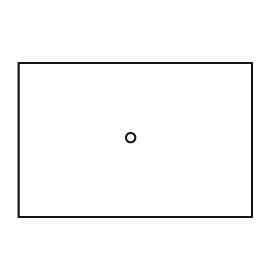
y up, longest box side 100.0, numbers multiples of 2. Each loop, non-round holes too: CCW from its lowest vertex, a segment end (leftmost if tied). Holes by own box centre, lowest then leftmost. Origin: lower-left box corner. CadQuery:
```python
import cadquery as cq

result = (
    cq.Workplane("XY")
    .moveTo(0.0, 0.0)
    .lineTo(100.0, 0.0)
    .lineTo(100.0, 66.0)
    .lineTo(0.0, 66.0)
    .close()
    .moveTo(48.0, 34.0)
    .circle(2.0)
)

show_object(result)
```